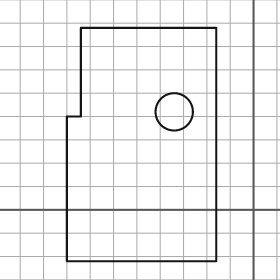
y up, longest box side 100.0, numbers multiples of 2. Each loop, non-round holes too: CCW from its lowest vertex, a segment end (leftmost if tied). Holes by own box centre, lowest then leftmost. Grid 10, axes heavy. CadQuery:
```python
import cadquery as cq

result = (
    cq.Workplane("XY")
    .moveTo(-80.0, -22.0)
    .lineTo(-16.0, -22.0)
    .lineTo(-16.0, 78.0)
    .lineTo(-74.0, 78.0)
    .lineTo(-74.0, 40.0)
    .lineTo(-80.0, 40.0)
    .close()
    .moveTo(-34.0, 42.0)
    .circle(8.0)
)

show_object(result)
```